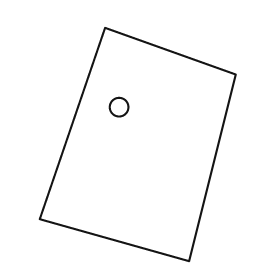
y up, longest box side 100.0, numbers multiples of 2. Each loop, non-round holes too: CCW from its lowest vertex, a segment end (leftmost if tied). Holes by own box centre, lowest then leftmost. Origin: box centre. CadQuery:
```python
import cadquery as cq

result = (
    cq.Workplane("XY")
    .moveTo(22.0, -50.0)
    .lineTo(42.0, 30.0)
    .lineTo(-14.0, 50.0)
    .lineTo(-42.0, -32.0)
    .close()
    .moveTo(-8.0, 16.0)
    .circle(4.0)
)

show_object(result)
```